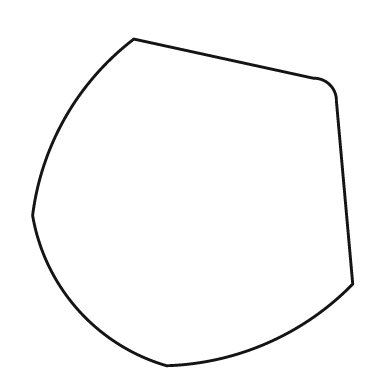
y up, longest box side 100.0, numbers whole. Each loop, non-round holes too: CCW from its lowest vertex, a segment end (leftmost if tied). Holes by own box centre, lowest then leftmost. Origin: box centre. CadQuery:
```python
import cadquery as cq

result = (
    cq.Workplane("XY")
    .moveTo(-8.0, -50.0)
    .threePointArc((23.0, -43.0), (49.0, -25.0))
    .lineTo(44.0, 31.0)
    .threePointArc((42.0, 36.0), (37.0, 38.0))
    .lineTo(-18.0, 50.0)
    .threePointArc((-39.0, 26.0), (-49.0, -4.0))
    .threePointArc((-35.0, -33.0), (-8.0, -50.0))
    .close()
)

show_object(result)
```